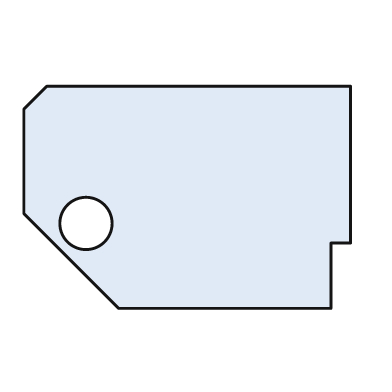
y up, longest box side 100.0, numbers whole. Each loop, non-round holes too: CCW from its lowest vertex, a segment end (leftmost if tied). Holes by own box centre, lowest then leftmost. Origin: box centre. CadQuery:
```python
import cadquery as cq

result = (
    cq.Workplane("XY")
    .moveTo(-21.0, -34.0)
    .lineTo(44.0, -34.0)
    .lineTo(44.0, -14.0)
    .lineTo(50.0, -14.0)
    .lineTo(50.0, 34.0)
    .lineTo(-43.0, 34.0)
    .lineTo(-50.0, 27.0)
    .lineTo(-50.0, -5.0)
    .close()
    .moveTo(-31.0, -8.0)
    .circle(8.0)
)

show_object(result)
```